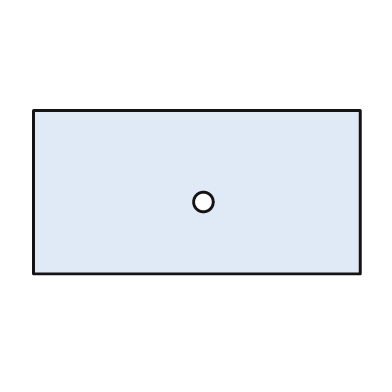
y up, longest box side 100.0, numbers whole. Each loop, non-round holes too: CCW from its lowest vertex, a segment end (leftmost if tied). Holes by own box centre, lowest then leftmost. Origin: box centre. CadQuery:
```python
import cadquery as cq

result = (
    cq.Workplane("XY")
    .moveTo(-50.0, -25.0)
    .lineTo(50.0, -25.0)
    .lineTo(50.0, 25.0)
    .lineTo(-50.0, 25.0)
    .close()
    .moveTo(2.0, -3.0)
    .circle(3.0)
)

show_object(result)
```